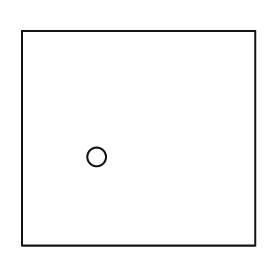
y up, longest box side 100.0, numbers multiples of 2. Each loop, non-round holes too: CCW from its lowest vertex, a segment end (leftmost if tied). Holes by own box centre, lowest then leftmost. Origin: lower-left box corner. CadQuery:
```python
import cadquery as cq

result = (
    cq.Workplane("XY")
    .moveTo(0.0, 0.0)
    .lineTo(100.0, 0.0)
    .lineTo(100.0, 92.0)
    .lineTo(0.0, 92.0)
    .close()
    .moveTo(32.0, 38.0)
    .circle(4.0)
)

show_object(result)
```